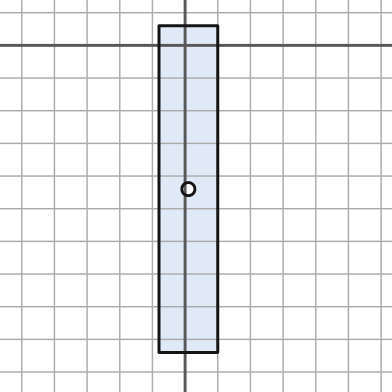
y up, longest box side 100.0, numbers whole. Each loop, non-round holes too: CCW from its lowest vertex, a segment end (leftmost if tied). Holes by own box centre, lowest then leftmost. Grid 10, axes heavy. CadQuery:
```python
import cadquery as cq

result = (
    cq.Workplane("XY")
    .moveTo(-8.0, -94.0)
    .lineTo(10.0, -94.0)
    .lineTo(10.0, 6.0)
    .lineTo(-8.0, 6.0)
    .close()
    .moveTo(1.0, -44.0)
    .circle(2.0)
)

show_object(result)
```